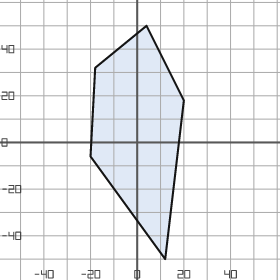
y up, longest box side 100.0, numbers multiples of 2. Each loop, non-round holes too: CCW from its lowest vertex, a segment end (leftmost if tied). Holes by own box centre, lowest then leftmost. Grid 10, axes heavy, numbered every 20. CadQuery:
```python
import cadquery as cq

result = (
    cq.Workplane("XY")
    .moveTo(12.0, -50.0)
    .lineTo(20.0, 18.0)
    .lineTo(4.0, 50.0)
    .lineTo(-18.0, 32.0)
    .lineTo(-20.0, -6.0)
    .close()
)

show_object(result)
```